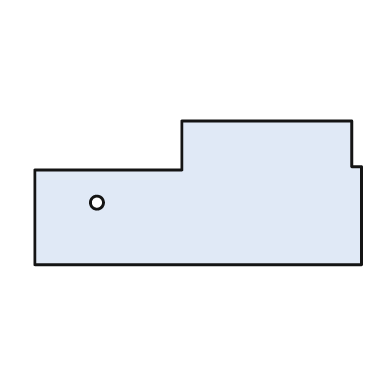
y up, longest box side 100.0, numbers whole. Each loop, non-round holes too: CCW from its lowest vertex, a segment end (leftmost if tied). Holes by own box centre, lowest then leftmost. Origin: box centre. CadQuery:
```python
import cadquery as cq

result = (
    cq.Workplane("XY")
    .moveTo(-50.0, -22.0)
    .lineTo(50.0, -22.0)
    .lineTo(50.0, 8.0)
    .lineTo(47.0, 8.0)
    .lineTo(47.0, 22.0)
    .lineTo(-5.0, 22.0)
    .lineTo(-5.0, 7.0)
    .lineTo(-50.0, 7.0)
    .close()
    .moveTo(-31.0, -3.0)
    .circle(2.0)
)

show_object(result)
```